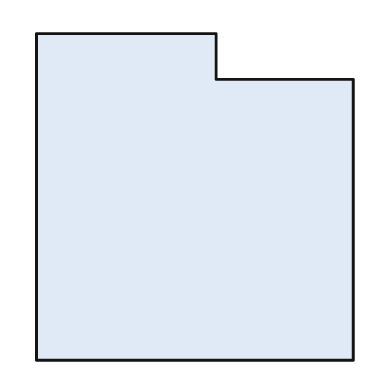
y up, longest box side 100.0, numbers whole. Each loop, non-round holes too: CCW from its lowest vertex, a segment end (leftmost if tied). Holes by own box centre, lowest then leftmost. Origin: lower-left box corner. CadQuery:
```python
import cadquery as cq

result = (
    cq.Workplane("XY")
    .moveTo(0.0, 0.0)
    .lineTo(97.0, 0.0)
    .lineTo(97.0, 86.0)
    .lineTo(55.0, 86.0)
    .lineTo(55.0, 100.0)
    .lineTo(0.0, 100.0)
    .close()
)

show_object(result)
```